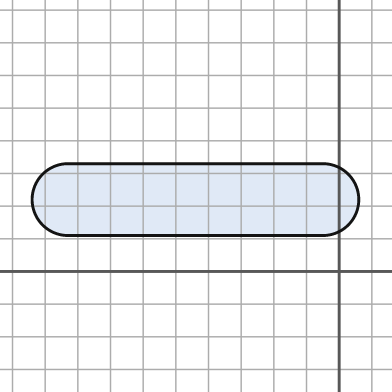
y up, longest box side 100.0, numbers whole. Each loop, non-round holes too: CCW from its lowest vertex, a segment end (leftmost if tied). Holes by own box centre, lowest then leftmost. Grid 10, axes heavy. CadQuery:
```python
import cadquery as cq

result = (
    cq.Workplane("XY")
    .moveTo(-83.0, 11.0)
    .lineTo(-5.0, 11.0)
    .threePointArc((6.0, 22.0), (-5.0, 33.0))
    .lineTo(-83.0, 33.0)
    .threePointArc((-94.0, 22.0), (-83.0, 11.0))
    .close()
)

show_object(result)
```